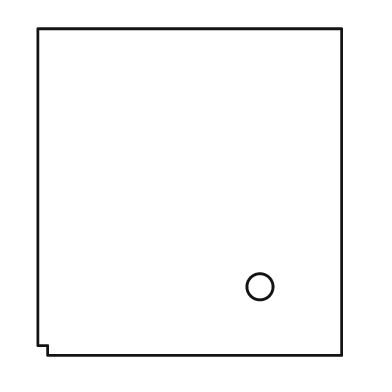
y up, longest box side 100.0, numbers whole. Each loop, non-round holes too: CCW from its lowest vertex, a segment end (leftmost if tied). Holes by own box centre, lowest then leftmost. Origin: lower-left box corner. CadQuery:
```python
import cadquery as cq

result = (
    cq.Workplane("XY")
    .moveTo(3.0, 0.0)
    .lineTo(93.0, 0.0)
    .lineTo(93.0, 100.0)
    .lineTo(0.0, 100.0)
    .lineTo(0.0, 3.0)
    .lineTo(3.0, 3.0)
    .close()
    .moveTo(68.0, 21.0)
    .circle(4.0)
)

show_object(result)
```